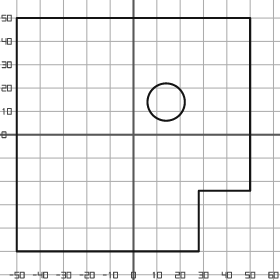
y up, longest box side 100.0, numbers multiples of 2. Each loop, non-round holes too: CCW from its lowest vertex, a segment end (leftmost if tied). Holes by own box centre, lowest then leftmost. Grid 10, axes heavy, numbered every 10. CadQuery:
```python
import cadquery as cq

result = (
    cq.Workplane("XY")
    .moveTo(-50.0, -50.0)
    .lineTo(28.0, -50.0)
    .lineTo(28.0, -24.0)
    .lineTo(50.0, -24.0)
    .lineTo(50.0, 50.0)
    .lineTo(-50.0, 50.0)
    .close()
    .moveTo(14.0, 14.0)
    .circle(8.0)
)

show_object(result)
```